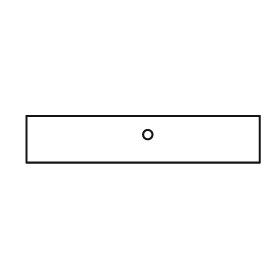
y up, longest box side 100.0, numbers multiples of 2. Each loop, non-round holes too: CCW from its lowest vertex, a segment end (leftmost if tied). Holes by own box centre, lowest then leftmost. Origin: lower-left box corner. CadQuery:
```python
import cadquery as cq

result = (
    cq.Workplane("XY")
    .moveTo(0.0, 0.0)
    .lineTo(100.0, 0.0)
    .lineTo(100.0, 20.0)
    .lineTo(0.0, 20.0)
    .close()
    .moveTo(52.0, 12.0)
    .circle(2.0)
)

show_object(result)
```